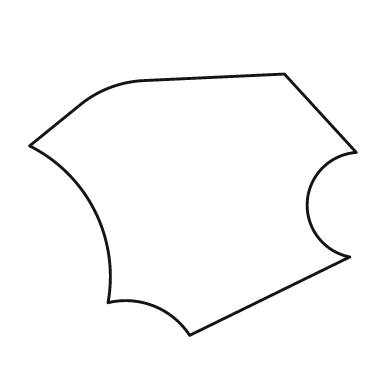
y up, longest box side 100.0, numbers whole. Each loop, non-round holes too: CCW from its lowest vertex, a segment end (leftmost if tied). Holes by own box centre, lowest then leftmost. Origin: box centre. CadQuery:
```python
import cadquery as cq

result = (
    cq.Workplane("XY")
    .moveTo(-1.0, -40.0)
    .lineTo(48.0, -16.0)
    .threePointArc((35.0, 1.0), (50.0, 16.0))
    .lineTo(28.0, 40.0)
    .lineTo(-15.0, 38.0)
    .threePointArc((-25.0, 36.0), (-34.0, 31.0))
    .lineTo(-50.0, 18.0)
    .threePointArc((-30.0, -2.0), (-26.0, -30.0))
    .threePointArc((-12.0, -31.0), (-1.0, -40.0))
    .close()
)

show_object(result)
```